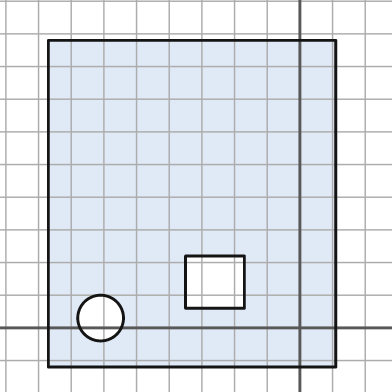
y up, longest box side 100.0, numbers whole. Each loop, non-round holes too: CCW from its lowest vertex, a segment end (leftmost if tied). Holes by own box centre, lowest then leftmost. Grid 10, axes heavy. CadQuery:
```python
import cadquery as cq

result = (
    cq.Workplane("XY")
    .moveTo(-77.0, -12.0)
    .lineTo(11.0, -12.0)
    .lineTo(11.0, 88.0)
    .lineTo(-77.0, 88.0)
    .close()
    .moveTo(-61.0, 3.0)
    .circle(7.0)
    .moveTo(-35.0, 6.0)
    .lineTo(-17.0, 6.0)
    .lineTo(-17.0, 22.0)
    .lineTo(-35.0, 22.0)
    .close()
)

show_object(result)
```